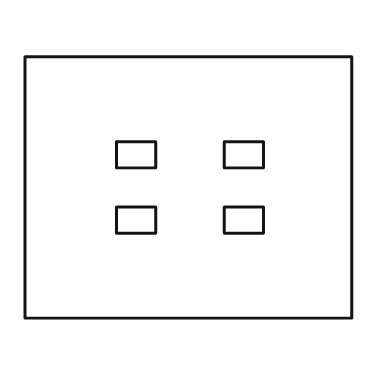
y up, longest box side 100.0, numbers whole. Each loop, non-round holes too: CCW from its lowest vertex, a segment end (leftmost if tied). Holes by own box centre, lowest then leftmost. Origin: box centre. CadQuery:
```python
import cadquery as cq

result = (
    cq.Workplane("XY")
    .moveTo(-50.0, -40.0)
    .lineTo(50.0, -40.0)
    .lineTo(50.0, 40.0)
    .lineTo(-50.0, 40.0)
    .close()
    .moveTo(-22.0, -14.0)
    .lineTo(-10.0, -14.0)
    .lineTo(-10.0, -6.0)
    .lineTo(-22.0, -6.0)
    .close()
    .moveTo(11.0, -14.0)
    .lineTo(23.0, -14.0)
    .lineTo(23.0, -6.0)
    .lineTo(11.0, -6.0)
    .close()
    .moveTo(-22.0, 6.0)
    .lineTo(-10.0, 6.0)
    .lineTo(-10.0, 14.0)
    .lineTo(-22.0, 14.0)
    .close()
    .moveTo(11.0, 6.0)
    .lineTo(23.0, 6.0)
    .lineTo(23.0, 14.0)
    .lineTo(11.0, 14.0)
    .close()
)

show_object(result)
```